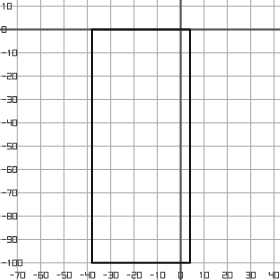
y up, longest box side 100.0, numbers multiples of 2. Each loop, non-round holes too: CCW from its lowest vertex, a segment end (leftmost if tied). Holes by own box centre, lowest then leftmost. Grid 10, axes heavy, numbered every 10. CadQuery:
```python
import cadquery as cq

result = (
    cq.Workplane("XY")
    .moveTo(-38.0, -100.0)
    .lineTo(4.0, -100.0)
    .lineTo(4.0, 0.0)
    .lineTo(-38.0, 0.0)
    .close()
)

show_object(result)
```